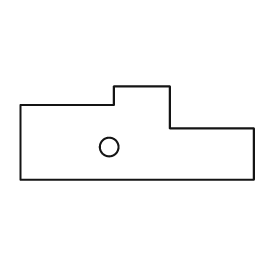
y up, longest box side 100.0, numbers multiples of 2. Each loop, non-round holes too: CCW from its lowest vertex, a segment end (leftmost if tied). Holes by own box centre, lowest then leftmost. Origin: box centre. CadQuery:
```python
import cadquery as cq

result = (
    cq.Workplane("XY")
    .moveTo(-50.0, -20.0)
    .lineTo(50.0, -20.0)
    .lineTo(50.0, 2.0)
    .lineTo(14.0, 2.0)
    .lineTo(14.0, 20.0)
    .lineTo(-10.0, 20.0)
    .lineTo(-10.0, 12.0)
    .lineTo(-50.0, 12.0)
    .close()
    .moveTo(-12.0, -6.0)
    .circle(4.0)
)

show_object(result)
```